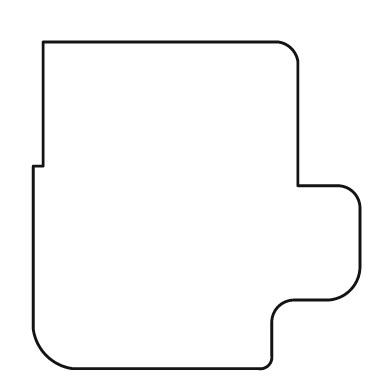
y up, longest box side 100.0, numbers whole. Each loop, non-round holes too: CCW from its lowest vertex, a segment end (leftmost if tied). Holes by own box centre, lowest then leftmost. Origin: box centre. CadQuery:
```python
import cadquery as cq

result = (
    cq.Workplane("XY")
    .moveTo(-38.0, -50.0)
    .lineTo(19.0, -50.0)
    .threePointArc((22.0, -49.0), (23.0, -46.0))
    .lineTo(23.0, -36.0)
    .threePointArc((25.0, -31.0), (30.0, -29.0))
    .lineTo(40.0, -29.0)
    .threePointArc((47.0, -26.0), (50.0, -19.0))
    .lineTo(50.0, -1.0)
    .threePointArc((48.0, 4.0), (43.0, 6.0))
    .lineTo(31.0, 6.0)
    .lineTo(31.0, 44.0)
    .threePointArc((29.0, 48.0), (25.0, 50.0))
    .lineTo(-47.0, 50.0)
    .lineTo(-47.0, 12.0)
    .lineTo(-50.0, 12.0)
    .lineTo(-50.0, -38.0)
    .threePointArc((-46.0, -46.0), (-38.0, -50.0))
    .close()
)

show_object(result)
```